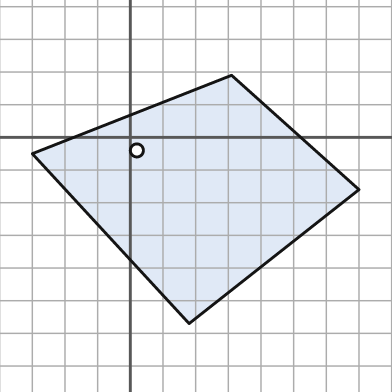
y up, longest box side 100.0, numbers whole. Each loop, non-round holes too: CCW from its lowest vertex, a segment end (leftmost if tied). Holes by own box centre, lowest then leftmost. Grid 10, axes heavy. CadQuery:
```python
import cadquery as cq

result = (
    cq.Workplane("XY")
    .moveTo(18.0, -57.0)
    .lineTo(70.0, -16.0)
    .lineTo(31.0, 19.0)
    .lineTo(-30.0, -5.0)
    .close()
    .moveTo(2.0, -4.0)
    .circle(2.0)
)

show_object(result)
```